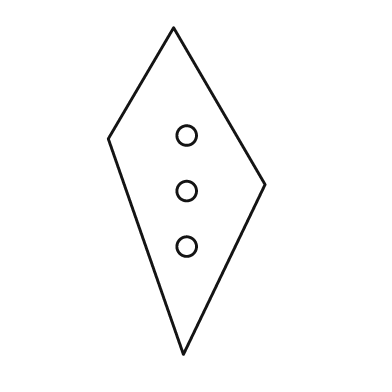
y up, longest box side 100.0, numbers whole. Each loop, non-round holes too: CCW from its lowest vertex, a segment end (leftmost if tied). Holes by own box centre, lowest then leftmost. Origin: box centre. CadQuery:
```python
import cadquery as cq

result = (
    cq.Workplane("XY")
    .moveTo(-1.0, -50.0)
    .lineTo(24.0, 2.0)
    .lineTo(-4.0, 50.0)
    .lineTo(-24.0, 16.0)
    .close()
    .moveTo(0.0, -17.0)
    .circle(3.0)
    .moveTo(0.0, 0.0)
    .circle(3.0)
    .moveTo(0.0, 17.0)
    .circle(3.0)
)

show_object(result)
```